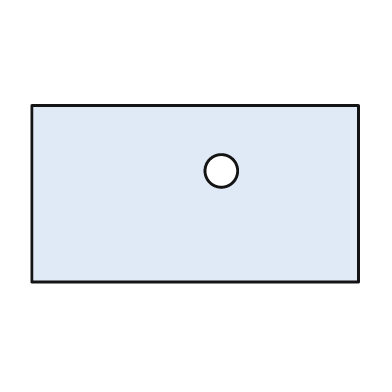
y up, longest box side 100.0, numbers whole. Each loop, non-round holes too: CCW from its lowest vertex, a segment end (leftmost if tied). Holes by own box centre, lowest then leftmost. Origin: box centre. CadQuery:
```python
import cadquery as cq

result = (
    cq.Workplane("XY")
    .moveTo(-50.0, -27.0)
    .lineTo(50.0, -27.0)
    .lineTo(50.0, 27.0)
    .lineTo(-50.0, 27.0)
    .close()
    .moveTo(8.0, 7.0)
    .circle(5.0)
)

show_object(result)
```